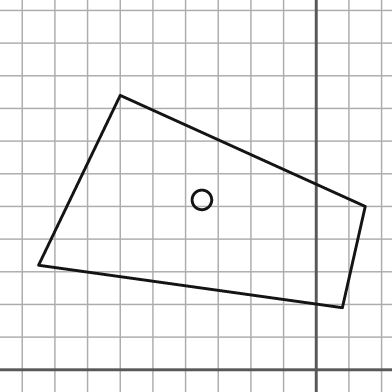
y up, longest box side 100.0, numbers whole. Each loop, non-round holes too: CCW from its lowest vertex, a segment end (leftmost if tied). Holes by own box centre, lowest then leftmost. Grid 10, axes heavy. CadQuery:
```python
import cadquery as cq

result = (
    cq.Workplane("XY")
    .moveTo(8.0, 19.0)
    .lineTo(15.0, 50.0)
    .lineTo(-60.0, 84.0)
    .lineTo(-85.0, 32.0)
    .close()
    .moveTo(-35.0, 52.0)
    .circle(3.0)
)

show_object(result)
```